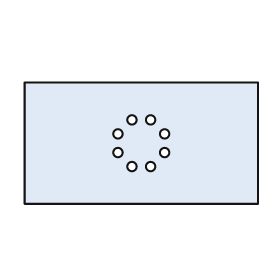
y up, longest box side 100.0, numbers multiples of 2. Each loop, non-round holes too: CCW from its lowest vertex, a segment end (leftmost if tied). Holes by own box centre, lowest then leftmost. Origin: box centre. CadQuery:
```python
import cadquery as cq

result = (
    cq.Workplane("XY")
    .moveTo(-50.0, -26.0)
    .lineTo(50.0, -26.0)
    .lineTo(50.0, 26.0)
    .lineTo(-50.0, 26.0)
    .close()
    .moveTo(-4.0, -10.0)
    .circle(2.0)
    .moveTo(4.0, -10.0)
    .circle(2.0)
    .moveTo(-10.0, -4.0)
    .circle(2.0)
    .moveTo(10.0, -4.0)
    .circle(2.0)
    .moveTo(-10.0, 4.0)
    .circle(2.0)
    .moveTo(10.0, 4.0)
    .circle(2.0)
    .moveTo(-4.0, 10.0)
    .circle(2.0)
    .moveTo(4.0, 10.0)
    .circle(2.0)
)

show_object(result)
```